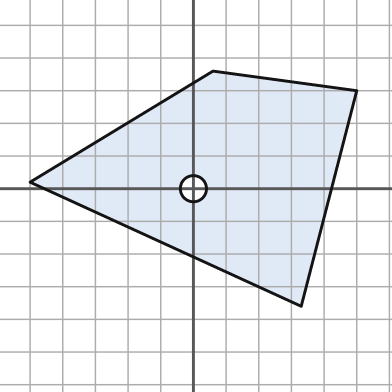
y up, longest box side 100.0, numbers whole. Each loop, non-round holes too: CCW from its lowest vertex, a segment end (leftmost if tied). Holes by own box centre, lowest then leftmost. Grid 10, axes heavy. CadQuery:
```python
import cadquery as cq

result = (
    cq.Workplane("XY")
    .moveTo(33.0, -36.0)
    .lineTo(50.0, 30.0)
    .lineTo(6.0, 36.0)
    .lineTo(-50.0, 2.0)
    .close()
    .moveTo(0.0, 0.0)
    .circle(4.0)
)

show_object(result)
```